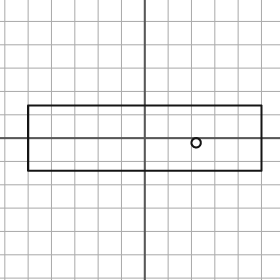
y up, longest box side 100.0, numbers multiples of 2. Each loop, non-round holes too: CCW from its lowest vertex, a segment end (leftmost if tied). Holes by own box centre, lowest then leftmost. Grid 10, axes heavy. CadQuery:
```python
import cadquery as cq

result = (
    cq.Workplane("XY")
    .moveTo(-50.0, -14.0)
    .lineTo(50.0, -14.0)
    .lineTo(50.0, 14.0)
    .lineTo(-50.0, 14.0)
    .close()
    .moveTo(22.0, -2.0)
    .circle(2.0)
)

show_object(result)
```